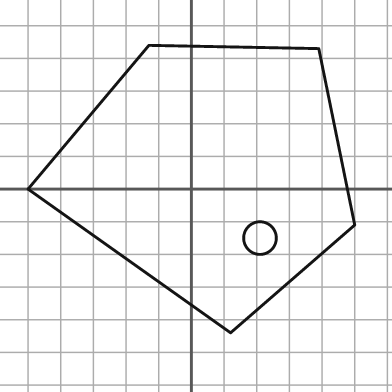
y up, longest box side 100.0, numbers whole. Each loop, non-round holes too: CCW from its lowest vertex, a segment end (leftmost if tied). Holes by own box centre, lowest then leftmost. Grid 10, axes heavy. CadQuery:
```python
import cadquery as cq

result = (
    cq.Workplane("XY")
    .moveTo(12.0, -44.0)
    .lineTo(50.0, -11.0)
    .lineTo(39.0, 43.0)
    .lineTo(-13.0, 44.0)
    .lineTo(-50.0, 0.0)
    .close()
    .moveTo(21.0, -15.0)
    .circle(5.0)
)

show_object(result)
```